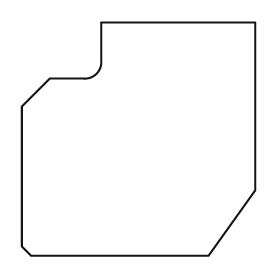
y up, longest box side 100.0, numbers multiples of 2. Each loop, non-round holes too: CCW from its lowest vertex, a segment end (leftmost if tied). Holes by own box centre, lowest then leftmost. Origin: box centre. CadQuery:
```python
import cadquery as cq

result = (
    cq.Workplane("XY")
    .moveTo(-46.0, -50.0)
    .lineTo(30.0, -50.0)
    .lineTo(50.0, -22.0)
    .lineTo(50.0, 50.0)
    .lineTo(-16.0, 50.0)
    .lineTo(-16.0, 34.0)
    .threePointArc((-18.0, 28.0), (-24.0, 26.0))
    .lineTo(-38.0, 26.0)
    .lineTo(-50.0, 14.0)
    .lineTo(-50.0, -46.0)
    .close()
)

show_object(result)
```